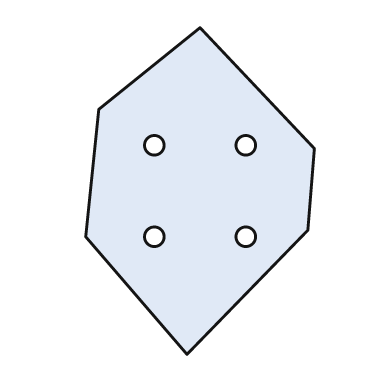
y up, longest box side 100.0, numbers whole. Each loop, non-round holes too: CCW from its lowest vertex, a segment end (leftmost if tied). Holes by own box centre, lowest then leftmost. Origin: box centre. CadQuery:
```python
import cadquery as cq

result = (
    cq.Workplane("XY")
    .moveTo(-4.0, -50.0)
    .lineTo(33.0, -12.0)
    .lineTo(35.0, 13.0)
    .lineTo(0.0, 50.0)
    .lineTo(-31.0, 25.0)
    .lineTo(-35.0, -14.0)
    .close()
    .moveTo(-14.0, -14.0)
    .circle(3.0)
    .moveTo(14.0, -14.0)
    .circle(3.0)
    .moveTo(-14.0, 14.0)
    .circle(3.0)
    .moveTo(14.0, 14.0)
    .circle(3.0)
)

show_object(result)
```